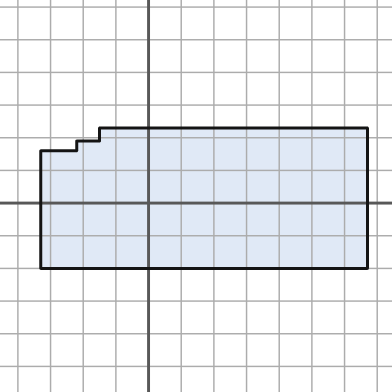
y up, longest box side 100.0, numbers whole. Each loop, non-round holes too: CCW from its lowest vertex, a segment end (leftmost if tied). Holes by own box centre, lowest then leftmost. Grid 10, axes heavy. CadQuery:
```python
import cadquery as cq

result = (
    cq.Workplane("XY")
    .moveTo(-33.0, -20.0)
    .lineTo(67.0, -20.0)
    .lineTo(67.0, 23.0)
    .lineTo(-15.0, 23.0)
    .lineTo(-15.0, 19.0)
    .lineTo(-22.0, 19.0)
    .lineTo(-22.0, 16.0)
    .lineTo(-33.0, 16.0)
    .close()
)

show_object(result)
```